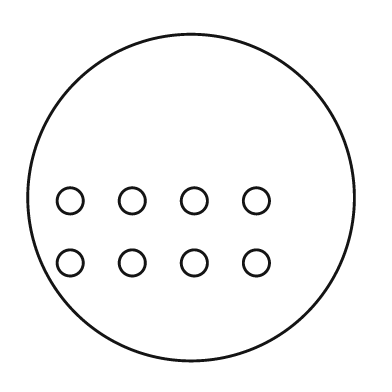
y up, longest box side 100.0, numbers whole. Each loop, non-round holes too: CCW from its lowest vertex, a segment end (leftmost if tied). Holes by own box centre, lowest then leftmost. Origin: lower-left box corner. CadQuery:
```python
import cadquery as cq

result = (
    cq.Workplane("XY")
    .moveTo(50.0, 50.0)
    .circle(50.0)
    .moveTo(13.0, 30.0)
    .circle(4.0)
    .moveTo(32.0, 30.0)
    .circle(4.0)
    .moveTo(51.0, 30.0)
    .circle(4.0)
    .moveTo(70.0, 30.0)
    .circle(4.0)
    .moveTo(13.0, 49.0)
    .circle(4.0)
    .moveTo(32.0, 49.0)
    .circle(4.0)
    .moveTo(51.0, 49.0)
    .circle(4.0)
    .moveTo(70.0, 49.0)
    .circle(4.0)
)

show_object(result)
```